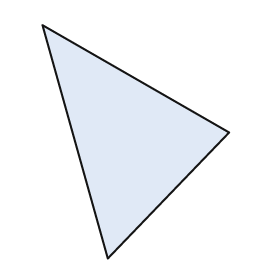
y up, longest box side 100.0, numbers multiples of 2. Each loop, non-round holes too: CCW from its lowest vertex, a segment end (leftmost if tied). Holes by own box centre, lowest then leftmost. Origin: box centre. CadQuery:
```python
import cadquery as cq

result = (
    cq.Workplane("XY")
    .moveTo(-12.0, -50.0)
    .lineTo(40.0, 4.0)
    .lineTo(-40.0, 50.0)
    .close()
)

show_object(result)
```